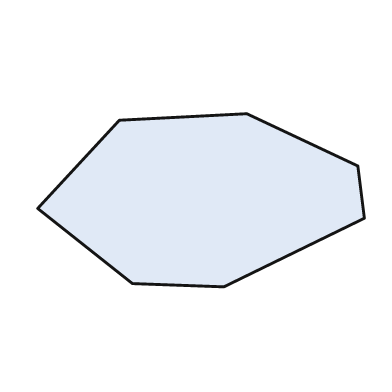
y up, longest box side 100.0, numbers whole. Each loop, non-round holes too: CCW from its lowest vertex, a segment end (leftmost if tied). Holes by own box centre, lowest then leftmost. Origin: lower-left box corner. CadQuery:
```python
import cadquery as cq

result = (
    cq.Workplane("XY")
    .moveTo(57.0, 0.0)
    .lineTo(100.0, 21.0)
    .lineTo(98.0, 37.0)
    .lineTo(64.0, 53.0)
    .lineTo(25.0, 51.0)
    .lineTo(0.0, 24.0)
    .lineTo(29.0, 1.0)
    .close()
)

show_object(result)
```